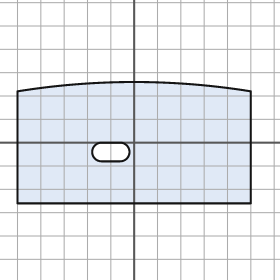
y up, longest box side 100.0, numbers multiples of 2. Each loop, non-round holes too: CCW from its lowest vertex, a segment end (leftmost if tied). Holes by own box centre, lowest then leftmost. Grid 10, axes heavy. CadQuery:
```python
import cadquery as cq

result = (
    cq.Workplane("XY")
    .moveTo(-50.0, -26.0)
    .lineTo(50.0, -26.0)
    .lineTo(50.0, 22.0)
    .threePointArc((0.0, 26.0), (-50.0, 22.0))
    .close()
    .moveTo(-14.0, -8.0)
    .lineTo(-6.0, -8.0)
    .threePointArc((-2.0, -4.0), (-6.0, 0.0))
    .lineTo(-14.0, 0.0)
    .threePointArc((-18.0, -4.0), (-14.0, -8.0))
    .close()
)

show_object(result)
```